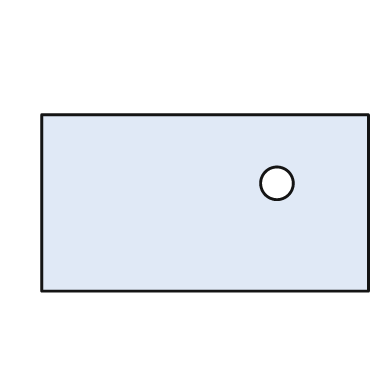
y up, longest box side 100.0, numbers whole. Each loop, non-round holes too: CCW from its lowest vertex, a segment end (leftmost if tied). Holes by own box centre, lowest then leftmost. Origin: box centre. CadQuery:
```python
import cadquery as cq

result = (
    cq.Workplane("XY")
    .moveTo(-50.0, -27.0)
    .lineTo(50.0, -27.0)
    .lineTo(50.0, 27.0)
    .lineTo(-50.0, 27.0)
    .close()
    .moveTo(22.0, 6.0)
    .circle(5.0)
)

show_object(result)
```